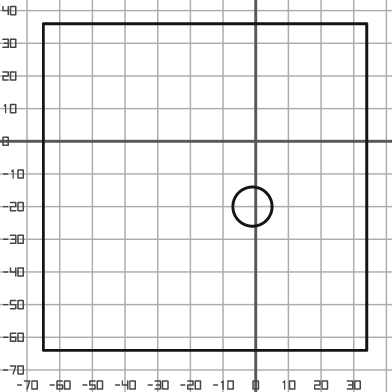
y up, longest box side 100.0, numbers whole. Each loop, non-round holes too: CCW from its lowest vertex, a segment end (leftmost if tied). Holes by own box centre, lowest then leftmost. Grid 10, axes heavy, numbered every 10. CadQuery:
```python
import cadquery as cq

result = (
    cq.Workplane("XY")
    .moveTo(-65.0, -64.0)
    .lineTo(34.0, -64.0)
    .lineTo(34.0, 36.0)
    .lineTo(-65.0, 36.0)
    .close()
    .moveTo(-1.0, -20.0)
    .circle(6.0)
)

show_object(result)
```